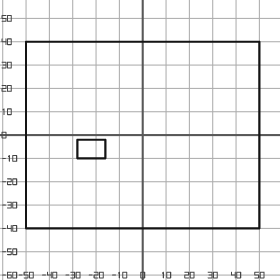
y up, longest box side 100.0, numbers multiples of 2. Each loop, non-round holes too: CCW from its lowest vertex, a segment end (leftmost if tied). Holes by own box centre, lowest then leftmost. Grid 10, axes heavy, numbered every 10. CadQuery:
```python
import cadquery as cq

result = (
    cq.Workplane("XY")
    .moveTo(-50.0, -40.0)
    .lineTo(50.0, -40.0)
    .lineTo(50.0, 40.0)
    .lineTo(-50.0, 40.0)
    .close()
    .moveTo(-28.0, -10.0)
    .lineTo(-16.0, -10.0)
    .lineTo(-16.0, -2.0)
    .lineTo(-28.0, -2.0)
    .close()
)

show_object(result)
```